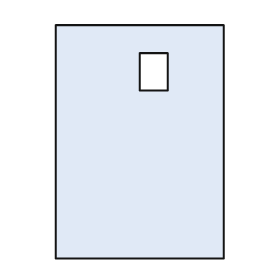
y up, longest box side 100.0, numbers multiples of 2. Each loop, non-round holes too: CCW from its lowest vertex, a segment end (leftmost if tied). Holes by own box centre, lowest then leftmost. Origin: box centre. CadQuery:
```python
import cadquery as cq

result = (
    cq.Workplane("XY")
    .moveTo(-36.0, -50.0)
    .lineTo(36.0, -50.0)
    .lineTo(36.0, 50.0)
    .lineTo(-36.0, 50.0)
    .close()
    .moveTo(0.0, 22.0)
    .lineTo(12.0, 22.0)
    .lineTo(12.0, 38.0)
    .lineTo(0.0, 38.0)
    .close()
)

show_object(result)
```